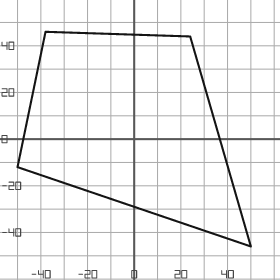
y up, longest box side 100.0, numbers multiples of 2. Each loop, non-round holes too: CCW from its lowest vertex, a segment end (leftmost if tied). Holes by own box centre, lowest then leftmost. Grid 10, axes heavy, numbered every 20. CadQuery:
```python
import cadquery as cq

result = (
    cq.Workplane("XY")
    .moveTo(50.0, -46.0)
    .lineTo(24.0, 44.0)
    .lineTo(-38.0, 46.0)
    .lineTo(-50.0, -12.0)
    .close()
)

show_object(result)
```